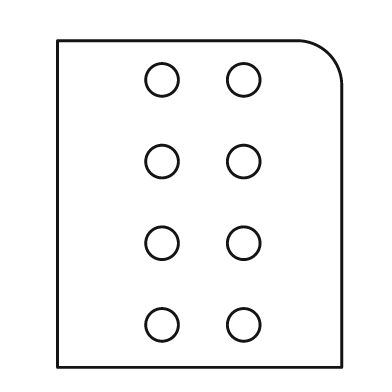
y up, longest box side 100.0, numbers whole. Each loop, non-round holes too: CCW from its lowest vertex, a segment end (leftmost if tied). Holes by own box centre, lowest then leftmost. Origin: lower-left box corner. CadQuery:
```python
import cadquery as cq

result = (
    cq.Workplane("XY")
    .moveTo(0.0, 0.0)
    .lineTo(87.0, 0.0)
    .lineTo(87.0, 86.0)
    .threePointArc((83.0, 96.0), (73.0, 100.0))
    .lineTo(0.0, 100.0)
    .close()
    .moveTo(32.0, 13.0)
    .circle(5.0)
    .moveTo(57.0, 13.0)
    .circle(5.0)
    .moveTo(32.0, 38.0)
    .circle(5.0)
    .moveTo(57.0, 38.0)
    .circle(5.0)
    .moveTo(32.0, 63.0)
    .circle(5.0)
    .moveTo(57.0, 63.0)
    .circle(5.0)
    .moveTo(32.0, 88.0)
    .circle(5.0)
    .moveTo(57.0, 88.0)
    .circle(5.0)
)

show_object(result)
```